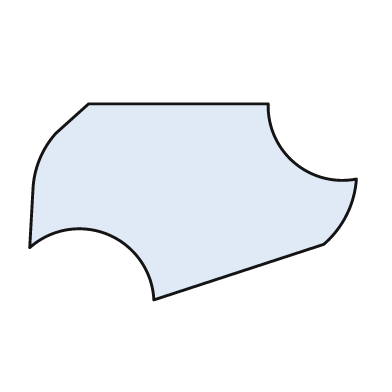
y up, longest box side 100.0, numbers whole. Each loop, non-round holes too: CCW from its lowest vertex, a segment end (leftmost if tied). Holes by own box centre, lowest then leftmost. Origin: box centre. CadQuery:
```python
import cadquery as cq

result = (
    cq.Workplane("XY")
    .moveTo(-12.0, -30.0)
    .lineTo(40.0, -13.0)
    .threePointArc((47.0, -4.0), (50.0, 7.0))
    .threePointArc((31.0, 12.0), (23.0, 30.0))
    .lineTo(-32.0, 30.0)
    .lineTo(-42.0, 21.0)
    .threePointArc((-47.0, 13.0), (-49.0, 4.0))
    .lineTo(-50.0, -14.0)
    .threePointArc((-26.0, -10.0), (-12.0, -30.0))
    .close()
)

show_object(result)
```